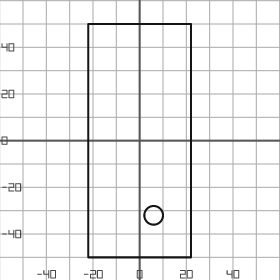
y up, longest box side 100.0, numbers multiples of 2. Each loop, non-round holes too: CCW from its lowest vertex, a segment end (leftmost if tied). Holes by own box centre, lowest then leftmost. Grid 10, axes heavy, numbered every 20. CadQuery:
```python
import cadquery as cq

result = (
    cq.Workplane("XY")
    .moveTo(-22.0, -50.0)
    .lineTo(22.0, -50.0)
    .lineTo(22.0, 50.0)
    .lineTo(-22.0, 50.0)
    .close()
    .moveTo(6.0, -32.0)
    .circle(4.0)
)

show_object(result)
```